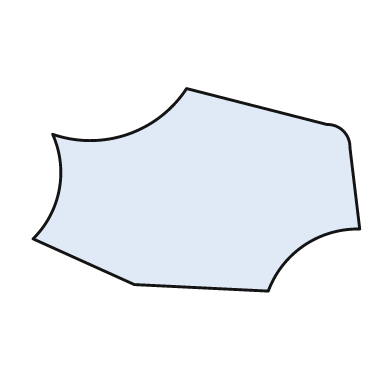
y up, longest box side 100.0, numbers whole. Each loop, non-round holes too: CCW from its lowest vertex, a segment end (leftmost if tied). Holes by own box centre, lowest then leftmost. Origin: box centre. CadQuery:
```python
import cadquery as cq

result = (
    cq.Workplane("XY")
    .moveTo(22.0, -31.0)
    .threePointArc((33.0, -17.0), (50.0, -12.0))
    .lineTo(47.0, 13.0)
    .threePointArc((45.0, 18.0), (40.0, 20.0))
    .lineTo(-3.0, 31.0)
    .threePointArc((-21.0, 17.0), (-44.0, 17.0))
    .threePointArc((-42.0, 0.0), (-50.0, -15.0))
    .lineTo(-19.0, -29.0)
    .close()
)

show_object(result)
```